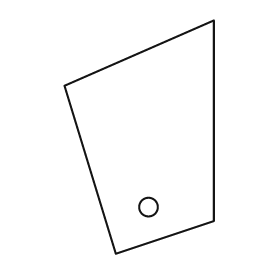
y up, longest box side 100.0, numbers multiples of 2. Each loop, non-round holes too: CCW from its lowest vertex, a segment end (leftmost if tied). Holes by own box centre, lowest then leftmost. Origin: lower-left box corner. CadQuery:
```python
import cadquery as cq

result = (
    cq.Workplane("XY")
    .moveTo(22.0, 0.0)
    .lineTo(64.0, 14.0)
    .lineTo(64.0, 100.0)
    .lineTo(0.0, 72.0)
    .close()
    .moveTo(36.0, 20.0)
    .circle(4.0)
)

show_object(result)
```